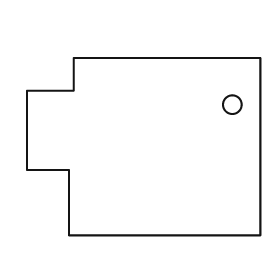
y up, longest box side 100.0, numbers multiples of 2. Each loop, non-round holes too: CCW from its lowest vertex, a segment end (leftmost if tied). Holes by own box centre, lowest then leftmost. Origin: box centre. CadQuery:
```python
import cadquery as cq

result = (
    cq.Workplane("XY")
    .moveTo(-32.0, -38.0)
    .lineTo(50.0, -38.0)
    .lineTo(50.0, 38.0)
    .lineTo(-30.0, 38.0)
    .lineTo(-30.0, 24.0)
    .lineTo(-50.0, 24.0)
    .lineTo(-50.0, -10.0)
    .lineTo(-32.0, -10.0)
    .close()
    .moveTo(38.0, 18.0)
    .circle(4.0)
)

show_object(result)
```